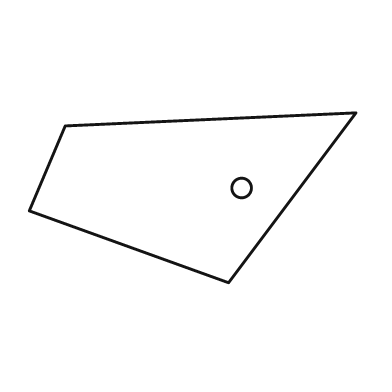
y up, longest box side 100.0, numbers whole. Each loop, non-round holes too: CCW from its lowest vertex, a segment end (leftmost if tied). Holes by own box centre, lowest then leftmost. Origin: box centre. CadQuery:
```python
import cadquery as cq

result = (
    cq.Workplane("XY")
    .moveTo(11.0, -26.0)
    .lineTo(50.0, 26.0)
    .lineTo(-39.0, 22.0)
    .lineTo(-50.0, -4.0)
    .close()
    .moveTo(15.0, 3.0)
    .circle(3.0)
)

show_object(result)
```